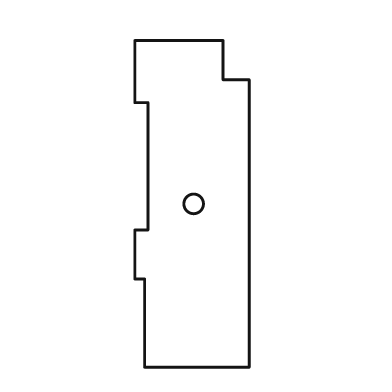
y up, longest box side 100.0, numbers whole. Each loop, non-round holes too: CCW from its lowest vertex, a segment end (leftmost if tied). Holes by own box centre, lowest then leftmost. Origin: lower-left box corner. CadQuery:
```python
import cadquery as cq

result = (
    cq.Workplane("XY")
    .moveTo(3.0, 0.0)
    .lineTo(35.0, 0.0)
    .lineTo(35.0, 88.0)
    .lineTo(27.0, 88.0)
    .lineTo(27.0, 100.0)
    .lineTo(0.0, 100.0)
    .lineTo(0.0, 81.0)
    .lineTo(4.0, 81.0)
    .lineTo(4.0, 42.0)
    .lineTo(0.0, 42.0)
    .lineTo(0.0, 27.0)
    .lineTo(3.0, 27.0)
    .close()
    .moveTo(18.0, 50.0)
    .circle(3.0)
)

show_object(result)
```